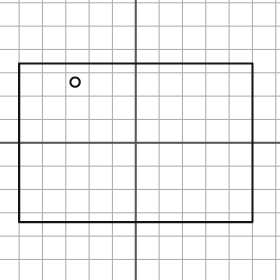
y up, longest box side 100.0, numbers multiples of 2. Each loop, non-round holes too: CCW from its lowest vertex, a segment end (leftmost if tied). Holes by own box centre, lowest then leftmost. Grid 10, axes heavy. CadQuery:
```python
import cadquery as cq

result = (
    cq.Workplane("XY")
    .moveTo(-50.0, -34.0)
    .lineTo(50.0, -34.0)
    .lineTo(50.0, 34.0)
    .lineTo(-50.0, 34.0)
    .close()
    .moveTo(-26.0, 26.0)
    .circle(2.0)
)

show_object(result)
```